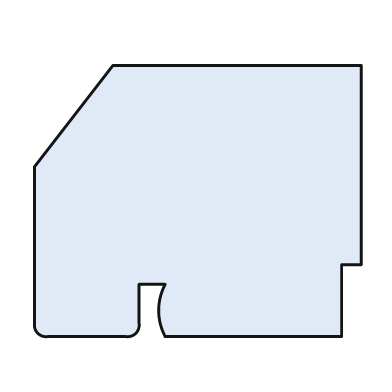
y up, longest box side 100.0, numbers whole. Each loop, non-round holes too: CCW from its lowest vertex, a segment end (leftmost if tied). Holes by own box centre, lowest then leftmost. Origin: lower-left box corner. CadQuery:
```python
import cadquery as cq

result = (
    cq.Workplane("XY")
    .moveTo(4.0, 0.0)
    .lineTo(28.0, 0.0)
    .threePointArc((31.0, 1.0), (32.0, 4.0))
    .lineTo(32.0, 16.0)
    .lineTo(40.0, 16.0)
    .threePointArc((38.0, 8.0), (40.0, 0.0))
    .lineTo(94.0, 0.0)
    .lineTo(94.0, 22.0)
    .lineTo(100.0, 22.0)
    .lineTo(100.0, 83.0)
    .lineTo(24.0, 83.0)
    .lineTo(0.0, 52.0)
    .lineTo(0.0, 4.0)
    .threePointArc((1.0, 1.0), (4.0, 0.0))
    .close()
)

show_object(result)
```